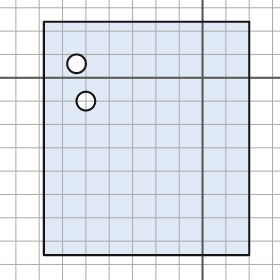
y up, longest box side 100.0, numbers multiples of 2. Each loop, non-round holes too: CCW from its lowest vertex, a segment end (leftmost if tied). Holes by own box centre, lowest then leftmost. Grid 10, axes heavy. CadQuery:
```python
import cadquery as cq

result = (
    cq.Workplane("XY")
    .moveTo(-68.0, -76.0)
    .lineTo(20.0, -76.0)
    .lineTo(20.0, 24.0)
    .lineTo(-68.0, 24.0)
    .close()
    .moveTo(-50.0, -10.0)
    .circle(4.0)
    .moveTo(-54.0, 6.0)
    .circle(4.0)
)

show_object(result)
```